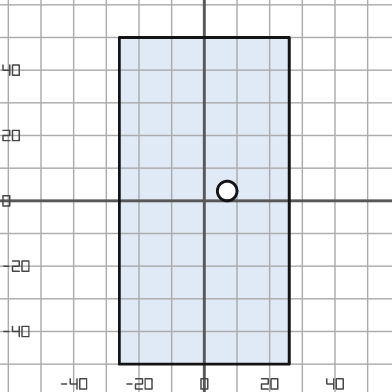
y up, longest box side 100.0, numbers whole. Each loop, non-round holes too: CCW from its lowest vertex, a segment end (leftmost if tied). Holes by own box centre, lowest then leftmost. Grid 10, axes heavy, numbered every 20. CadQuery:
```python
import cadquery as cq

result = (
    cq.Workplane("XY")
    .moveTo(-26.0, -50.0)
    .lineTo(26.0, -50.0)
    .lineTo(26.0, 50.0)
    .lineTo(-26.0, 50.0)
    .close()
    .moveTo(7.0, 3.0)
    .circle(3.0)
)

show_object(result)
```